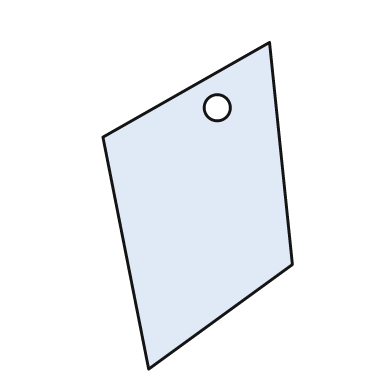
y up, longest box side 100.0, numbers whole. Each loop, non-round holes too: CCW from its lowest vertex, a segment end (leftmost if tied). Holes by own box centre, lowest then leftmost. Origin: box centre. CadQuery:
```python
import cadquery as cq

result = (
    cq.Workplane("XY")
    .moveTo(-15.0, -50.0)
    .lineTo(29.0, -18.0)
    .lineTo(22.0, 50.0)
    .lineTo(-29.0, 21.0)
    .close()
    .moveTo(6.0, 30.0)
    .circle(4.0)
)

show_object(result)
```